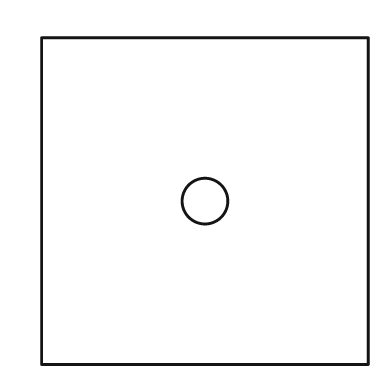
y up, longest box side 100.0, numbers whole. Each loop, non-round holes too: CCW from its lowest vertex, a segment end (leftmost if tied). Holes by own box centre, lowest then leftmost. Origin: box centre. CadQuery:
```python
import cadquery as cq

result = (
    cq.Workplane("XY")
    .moveTo(-50.0, -50.0)
    .lineTo(50.0, -50.0)
    .lineTo(50.0, 50.0)
    .lineTo(-50.0, 50.0)
    .close()
    .moveTo(0.0, 0.0)
    .circle(7.0)
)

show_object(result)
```